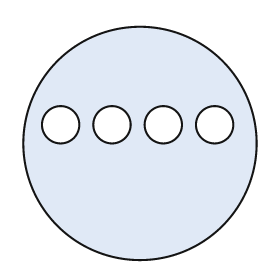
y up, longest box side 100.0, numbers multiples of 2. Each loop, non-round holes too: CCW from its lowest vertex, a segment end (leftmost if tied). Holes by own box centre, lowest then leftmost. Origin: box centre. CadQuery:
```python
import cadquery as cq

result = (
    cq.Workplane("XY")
    .moveTo(0.0, 0.0)
    .circle(50.0)
    .moveTo(-34.0, 8.0)
    .circle(8.0)
    .moveTo(-12.0, 8.0)
    .circle(8.0)
    .moveTo(10.0, 8.0)
    .circle(8.0)
    .moveTo(32.0, 8.0)
    .circle(8.0)
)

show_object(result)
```